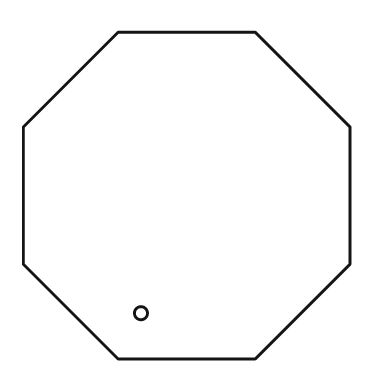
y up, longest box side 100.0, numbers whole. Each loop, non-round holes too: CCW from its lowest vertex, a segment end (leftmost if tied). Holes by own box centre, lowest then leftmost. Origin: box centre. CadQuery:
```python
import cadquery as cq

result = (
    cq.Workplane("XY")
    .moveTo(-21.0, -50.0)
    .lineTo(21.0, -50.0)
    .lineTo(50.0, -21.0)
    .lineTo(50.0, 21.0)
    .lineTo(21.0, 50.0)
    .lineTo(-21.0, 50.0)
    .lineTo(-50.0, 21.0)
    .lineTo(-50.0, -21.0)
    .close()
    .moveTo(-14.0, -36.0)
    .circle(2.0)
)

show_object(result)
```